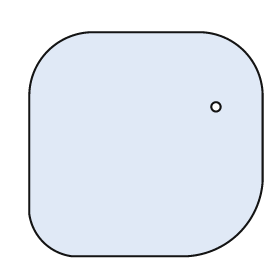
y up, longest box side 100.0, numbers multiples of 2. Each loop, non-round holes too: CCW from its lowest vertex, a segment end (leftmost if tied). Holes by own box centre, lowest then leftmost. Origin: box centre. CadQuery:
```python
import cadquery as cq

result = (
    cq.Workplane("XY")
    .moveTo(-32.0, -48.0)
    .lineTo(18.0, -48.0)
    .threePointArc((40.0, -38.0), (50.0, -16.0))
    .lineTo(50.0, 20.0)
    .threePointArc((42.0, 40.0), (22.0, 48.0))
    .lineTo(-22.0, 48.0)
    .threePointArc((-42.0, 40.0), (-50.0, 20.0))
    .lineTo(-50.0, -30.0)
    .threePointArc((-44.0, -42.0), (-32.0, -48.0))
    .close()
    .moveTo(30.0, 16.0)
    .circle(2.0)
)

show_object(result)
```